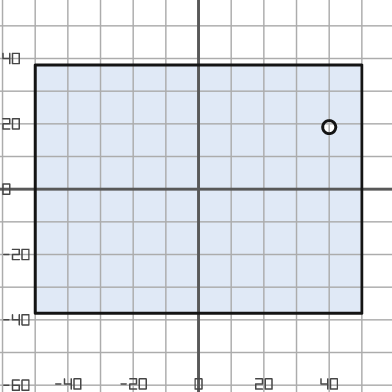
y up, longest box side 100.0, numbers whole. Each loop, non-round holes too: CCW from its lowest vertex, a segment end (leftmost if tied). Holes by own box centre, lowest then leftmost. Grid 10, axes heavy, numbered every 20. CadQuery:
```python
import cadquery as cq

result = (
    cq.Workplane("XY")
    .moveTo(-50.0, -38.0)
    .lineTo(50.0, -38.0)
    .lineTo(50.0, 38.0)
    .lineTo(-50.0, 38.0)
    .close()
    .moveTo(40.0, 19.0)
    .circle(2.0)
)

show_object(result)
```